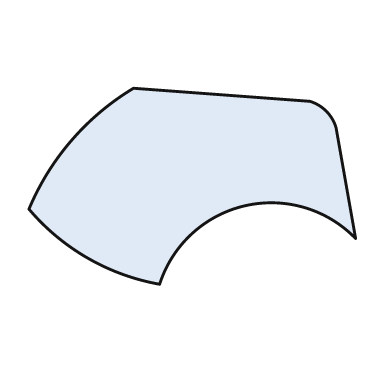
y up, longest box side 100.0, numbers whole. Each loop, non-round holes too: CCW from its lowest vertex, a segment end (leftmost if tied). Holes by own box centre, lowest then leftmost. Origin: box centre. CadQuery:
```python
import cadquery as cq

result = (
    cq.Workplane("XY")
    .moveTo(-10.0, -30.0)
    .threePointArc((16.0, -6.0), (50.0, -16.0))
    .lineTo(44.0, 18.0)
    .threePointArc((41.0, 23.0), (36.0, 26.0))
    .lineTo(-18.0, 30.0)
    .threePointArc((-37.0, 14.0), (-50.0, -7.0))
    .threePointArc((-32.0, -22.0), (-10.0, -30.0))
    .close()
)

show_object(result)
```